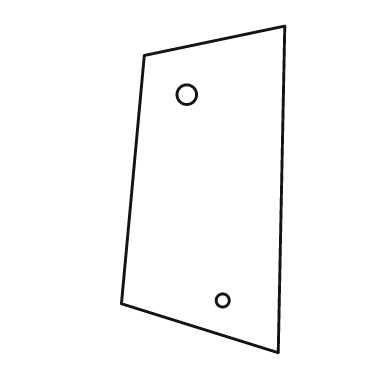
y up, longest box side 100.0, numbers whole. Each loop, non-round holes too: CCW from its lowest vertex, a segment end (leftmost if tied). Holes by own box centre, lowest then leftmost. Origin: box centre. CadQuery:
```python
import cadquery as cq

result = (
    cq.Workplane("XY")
    .moveTo(23.0, -50.0)
    .lineTo(25.0, 50.0)
    .lineTo(-18.0, 41.0)
    .lineTo(-25.0, -35.0)
    .close()
    .moveTo(6.0, -34.0)
    .circle(2.0)
    .moveTo(-5.0, 29.0)
    .circle(3.0)
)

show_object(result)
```